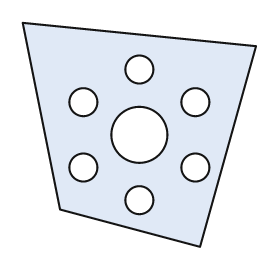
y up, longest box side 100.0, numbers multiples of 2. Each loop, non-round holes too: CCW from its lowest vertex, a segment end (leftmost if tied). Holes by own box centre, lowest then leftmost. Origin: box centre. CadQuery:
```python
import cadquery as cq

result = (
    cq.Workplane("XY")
    .moveTo(26.0, -48.0)
    .lineTo(50.0, 38.0)
    .lineTo(-50.0, 48.0)
    .lineTo(-34.0, -32.0)
    .close()
    .moveTo(0.0, -28.0)
    .circle(6.0)
    .moveTo(-24.0, -14.0)
    .circle(6.0)
    .moveTo(24.0, -14.0)
    .circle(6.0)
    .moveTo(0.0, 0.0)
    .circle(12.0)
    .moveTo(-24.0, 14.0)
    .circle(6.0)
    .moveTo(24.0, 14.0)
    .circle(6.0)
    .moveTo(0.0, 28.0)
    .circle(6.0)
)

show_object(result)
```